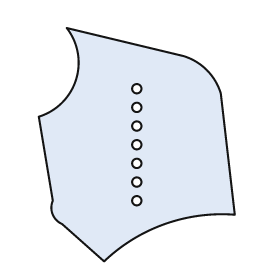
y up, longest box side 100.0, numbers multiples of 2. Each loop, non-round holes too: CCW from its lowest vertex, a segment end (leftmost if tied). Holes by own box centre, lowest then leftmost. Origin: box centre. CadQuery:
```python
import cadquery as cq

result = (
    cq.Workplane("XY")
    .moveTo(-14.0, -50.0)
    .threePointArc((12.0, -34.0), (42.0, -30.0))
    .lineTo(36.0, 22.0)
    .threePointArc((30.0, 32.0), (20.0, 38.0))
    .lineTo(-30.0, 50.0)
    .threePointArc((-26.0, 28.0), (-42.0, 12.0))
    .lineTo(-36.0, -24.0)
    .threePointArc((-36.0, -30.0), (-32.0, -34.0))
    .close()
    .moveTo(0.0, -24.0)
    .circle(2.0)
    .moveTo(0.0, -16.0)
    .circle(2.0)
    .moveTo(0.0, -8.0)
    .circle(2.0)
    .moveTo(0.0, 0.0)
    .circle(2.0)
    .moveTo(0.0, 8.0)
    .circle(2.0)
    .moveTo(0.0, 16.0)
    .circle(2.0)
    .moveTo(0.0, 24.0)
    .circle(2.0)
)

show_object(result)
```